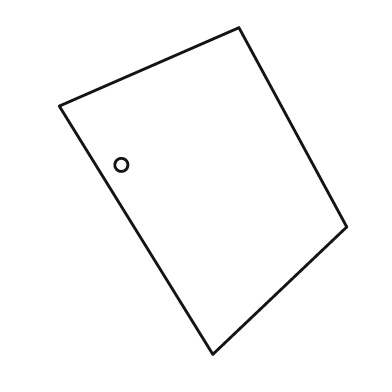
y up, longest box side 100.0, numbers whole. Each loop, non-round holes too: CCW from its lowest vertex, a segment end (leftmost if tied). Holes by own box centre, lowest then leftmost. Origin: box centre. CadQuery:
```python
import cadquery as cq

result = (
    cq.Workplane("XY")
    .moveTo(3.0, -50.0)
    .lineTo(44.0, -11.0)
    .lineTo(11.0, 50.0)
    .lineTo(-44.0, 26.0)
    .close()
    .moveTo(-25.0, 8.0)
    .circle(2.0)
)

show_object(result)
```